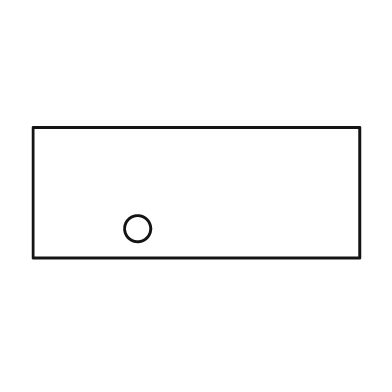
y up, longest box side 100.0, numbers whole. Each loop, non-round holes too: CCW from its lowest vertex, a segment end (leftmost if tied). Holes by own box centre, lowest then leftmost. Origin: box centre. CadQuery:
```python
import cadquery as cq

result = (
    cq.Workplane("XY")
    .moveTo(-50.0, -20.0)
    .lineTo(50.0, -20.0)
    .lineTo(50.0, 20.0)
    .lineTo(-50.0, 20.0)
    .close()
    .moveTo(-18.0, -11.0)
    .circle(4.0)
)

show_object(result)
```